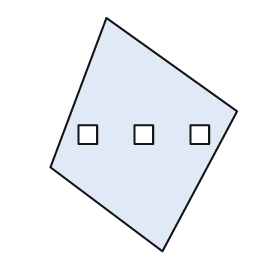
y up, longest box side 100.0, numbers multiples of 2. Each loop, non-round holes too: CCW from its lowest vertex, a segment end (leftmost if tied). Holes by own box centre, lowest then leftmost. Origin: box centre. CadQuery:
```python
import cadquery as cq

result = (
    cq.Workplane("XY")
    .moveTo(8.0, -50.0)
    .lineTo(40.0, 10.0)
    .lineTo(-16.0, 50.0)
    .lineTo(-40.0, -14.0)
    .close()
    .moveTo(-28.0, -4.0)
    .lineTo(-20.0, -4.0)
    .lineTo(-20.0, 4.0)
    .lineTo(-28.0, 4.0)
    .close()
    .moveTo(-4.0, -4.0)
    .lineTo(4.0, -4.0)
    .lineTo(4.0, 4.0)
    .lineTo(-4.0, 4.0)
    .close()
    .moveTo(20.0, -4.0)
    .lineTo(28.0, -4.0)
    .lineTo(28.0, 4.0)
    .lineTo(20.0, 4.0)
    .close()
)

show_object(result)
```